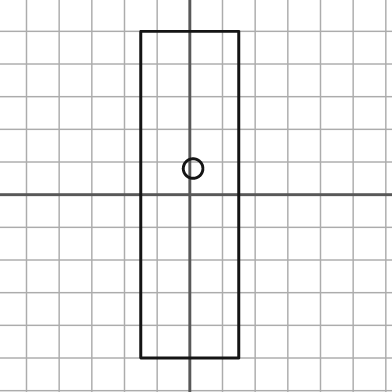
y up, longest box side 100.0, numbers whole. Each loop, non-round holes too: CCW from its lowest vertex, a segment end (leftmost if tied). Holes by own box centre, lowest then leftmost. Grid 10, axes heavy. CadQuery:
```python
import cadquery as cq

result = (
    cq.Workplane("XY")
    .moveTo(-15.0, -50.0)
    .lineTo(15.0, -50.0)
    .lineTo(15.0, 50.0)
    .lineTo(-15.0, 50.0)
    .close()
    .moveTo(1.0, 8.0)
    .circle(3.0)
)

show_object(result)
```